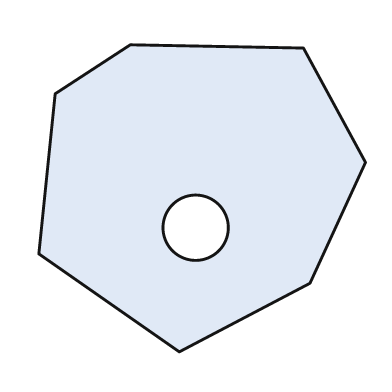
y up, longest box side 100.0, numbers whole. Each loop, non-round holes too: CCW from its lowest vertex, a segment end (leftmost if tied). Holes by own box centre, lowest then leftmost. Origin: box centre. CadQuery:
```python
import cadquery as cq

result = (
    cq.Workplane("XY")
    .moveTo(-7.0, -47.0)
    .lineTo(33.0, -26.0)
    .lineTo(50.0, 11.0)
    .lineTo(31.0, 46.0)
    .lineTo(-22.0, 47.0)
    .lineTo(-45.0, 32.0)
    .lineTo(-50.0, -17.0)
    .close()
    .moveTo(-2.0, -9.0)
    .circle(10.0)
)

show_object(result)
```